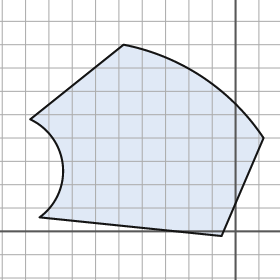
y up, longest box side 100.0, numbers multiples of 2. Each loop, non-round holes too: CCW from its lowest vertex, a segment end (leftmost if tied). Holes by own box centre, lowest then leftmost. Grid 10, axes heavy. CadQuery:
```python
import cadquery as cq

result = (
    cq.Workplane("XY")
    .moveTo(-6.0, -2.0)
    .lineTo(12.0, 40.0)
    .threePointArc((-14.0, 66.0), (-48.0, 80.0))
    .lineTo(-88.0, 48.0)
    .threePointArc((-74.0, 28.0), (-84.0, 6.0))
    .close()
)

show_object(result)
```